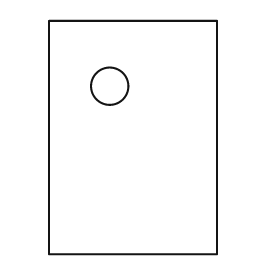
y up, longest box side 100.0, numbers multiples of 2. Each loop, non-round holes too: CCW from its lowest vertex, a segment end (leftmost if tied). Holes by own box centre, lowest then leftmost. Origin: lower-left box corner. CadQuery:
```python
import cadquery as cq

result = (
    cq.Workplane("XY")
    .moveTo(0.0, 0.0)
    .lineTo(72.0, 0.0)
    .lineTo(72.0, 100.0)
    .lineTo(0.0, 100.0)
    .close()
    .moveTo(26.0, 72.0)
    .circle(8.0)
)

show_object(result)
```